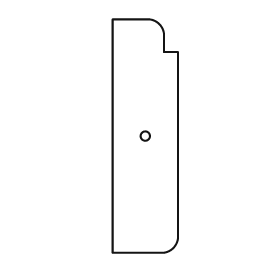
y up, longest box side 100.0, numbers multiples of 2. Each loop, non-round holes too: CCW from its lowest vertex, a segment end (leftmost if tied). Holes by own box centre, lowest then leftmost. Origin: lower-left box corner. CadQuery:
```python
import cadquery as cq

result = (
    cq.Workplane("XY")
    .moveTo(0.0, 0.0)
    .lineTo(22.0, 0.0)
    .threePointArc((26.0, 2.0), (28.0, 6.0))
    .lineTo(28.0, 86.0)
    .lineTo(22.0, 86.0)
    .lineTo(22.0, 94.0)
    .threePointArc((20.0, 98.0), (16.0, 100.0))
    .lineTo(0.0, 100.0)
    .close()
    .moveTo(14.0, 50.0)
    .circle(2.0)
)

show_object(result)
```